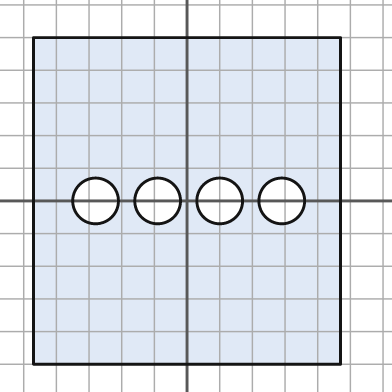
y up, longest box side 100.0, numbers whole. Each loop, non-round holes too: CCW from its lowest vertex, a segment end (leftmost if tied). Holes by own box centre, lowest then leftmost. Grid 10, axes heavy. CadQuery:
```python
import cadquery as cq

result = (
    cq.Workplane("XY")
    .moveTo(-47.0, -50.0)
    .lineTo(47.0, -50.0)
    .lineTo(47.0, 50.0)
    .lineTo(-47.0, 50.0)
    .close()
    .moveTo(-28.0, 0.0)
    .circle(7.0)
    .moveTo(-9.0, 0.0)
    .circle(7.0)
    .moveTo(10.0, 0.0)
    .circle(7.0)
    .moveTo(29.0, 0.0)
    .circle(7.0)
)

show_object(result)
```